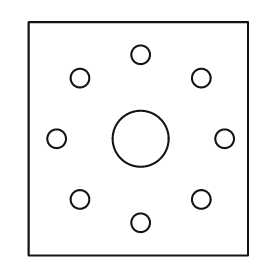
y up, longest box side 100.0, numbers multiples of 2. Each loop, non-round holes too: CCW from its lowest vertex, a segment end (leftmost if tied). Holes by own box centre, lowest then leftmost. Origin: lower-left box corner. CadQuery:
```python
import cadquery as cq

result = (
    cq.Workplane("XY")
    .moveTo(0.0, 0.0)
    .lineTo(94.0, 0.0)
    .lineTo(94.0, 100.0)
    .lineTo(0.0, 100.0)
    .close()
    .moveTo(48.0, 14.0)
    .circle(4.0)
    .moveTo(22.0, 24.0)
    .circle(4.0)
    .moveTo(74.0, 24.0)
    .circle(4.0)
    .moveTo(12.0, 50.0)
    .circle(4.0)
    .moveTo(48.0, 50.0)
    .circle(12.0)
    .moveTo(84.0, 50.0)
    .circle(4.0)
    .moveTo(22.0, 76.0)
    .circle(4.0)
    .moveTo(74.0, 76.0)
    .circle(4.0)
    .moveTo(48.0, 86.0)
    .circle(4.0)
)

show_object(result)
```